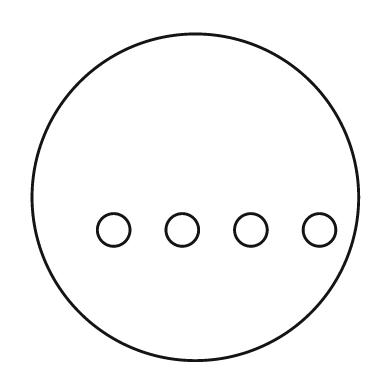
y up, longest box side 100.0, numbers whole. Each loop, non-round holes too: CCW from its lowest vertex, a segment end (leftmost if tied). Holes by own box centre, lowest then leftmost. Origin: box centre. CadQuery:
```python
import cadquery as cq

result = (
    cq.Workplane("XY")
    .moveTo(0.0, 0.0)
    .circle(50.0)
    .moveTo(-25.0, -10.0)
    .circle(5.0)
    .moveTo(-4.0, -10.0)
    .circle(5.0)
    .moveTo(17.0, -10.0)
    .circle(5.0)
    .moveTo(38.0, -10.0)
    .circle(5.0)
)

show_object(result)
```